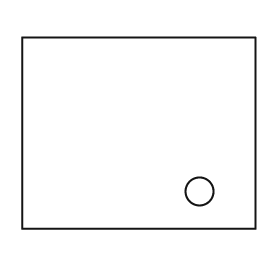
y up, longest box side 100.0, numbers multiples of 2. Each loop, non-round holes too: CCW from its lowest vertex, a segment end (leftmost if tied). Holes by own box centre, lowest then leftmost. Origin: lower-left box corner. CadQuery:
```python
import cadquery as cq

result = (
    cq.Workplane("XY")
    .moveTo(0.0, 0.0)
    .lineTo(100.0, 0.0)
    .lineTo(100.0, 82.0)
    .lineTo(0.0, 82.0)
    .close()
    .moveTo(76.0, 16.0)
    .circle(6.0)
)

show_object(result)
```